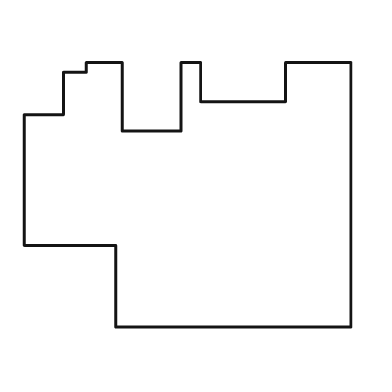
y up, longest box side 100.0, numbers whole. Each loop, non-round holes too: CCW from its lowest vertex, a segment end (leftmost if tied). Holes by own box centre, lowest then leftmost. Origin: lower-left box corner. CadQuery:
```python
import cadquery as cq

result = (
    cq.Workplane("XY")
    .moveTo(28.0, 0.0)
    .lineTo(100.0, 0.0)
    .lineTo(100.0, 81.0)
    .lineTo(80.0, 81.0)
    .lineTo(80.0, 69.0)
    .lineTo(54.0, 69.0)
    .lineTo(54.0, 81.0)
    .lineTo(48.0, 81.0)
    .lineTo(48.0, 60.0)
    .lineTo(30.0, 60.0)
    .lineTo(30.0, 81.0)
    .lineTo(19.0, 81.0)
    .lineTo(19.0, 78.0)
    .lineTo(12.0, 78.0)
    .lineTo(12.0, 65.0)
    .lineTo(0.0, 65.0)
    .lineTo(0.0, 25.0)
    .lineTo(28.0, 25.0)
    .close()
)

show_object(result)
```